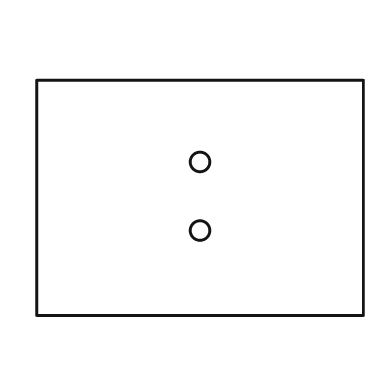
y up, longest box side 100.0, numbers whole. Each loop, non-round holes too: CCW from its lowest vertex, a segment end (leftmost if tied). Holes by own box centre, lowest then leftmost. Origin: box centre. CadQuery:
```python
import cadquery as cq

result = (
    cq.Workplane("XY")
    .moveTo(-50.0, -36.0)
    .lineTo(50.0, -36.0)
    .lineTo(50.0, 36.0)
    .lineTo(-50.0, 36.0)
    .close()
    .moveTo(0.0, -10.0)
    .circle(3.0)
    .moveTo(0.0, 11.0)
    .circle(3.0)
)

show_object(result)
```